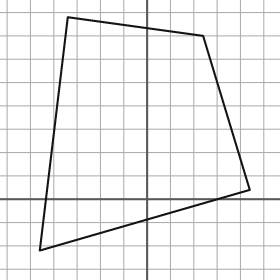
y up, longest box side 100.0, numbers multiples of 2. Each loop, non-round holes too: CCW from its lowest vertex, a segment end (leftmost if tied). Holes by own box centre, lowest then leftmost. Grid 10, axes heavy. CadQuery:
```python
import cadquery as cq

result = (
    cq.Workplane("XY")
    .moveTo(-46.0, -22.0)
    .lineTo(44.0, 4.0)
    .lineTo(24.0, 70.0)
    .lineTo(-34.0, 78.0)
    .close()
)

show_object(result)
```